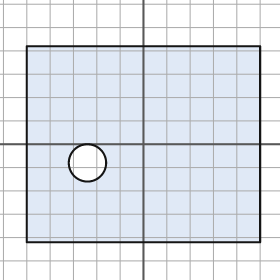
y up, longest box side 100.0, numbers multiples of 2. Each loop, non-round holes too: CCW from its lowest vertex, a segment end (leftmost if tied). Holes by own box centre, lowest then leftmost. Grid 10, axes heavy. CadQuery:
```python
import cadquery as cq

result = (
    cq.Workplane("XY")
    .moveTo(-50.0, -42.0)
    .lineTo(50.0, -42.0)
    .lineTo(50.0, 42.0)
    .lineTo(-50.0, 42.0)
    .close()
    .moveTo(-24.0, -8.0)
    .circle(8.0)
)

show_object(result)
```